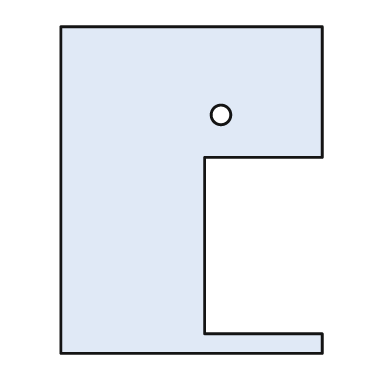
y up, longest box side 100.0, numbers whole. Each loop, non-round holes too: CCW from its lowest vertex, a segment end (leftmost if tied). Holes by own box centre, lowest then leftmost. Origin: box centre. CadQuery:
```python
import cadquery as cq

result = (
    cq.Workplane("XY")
    .moveTo(-40.0, -50.0)
    .lineTo(40.0, -50.0)
    .lineTo(40.0, -44.0)
    .lineTo(4.0, -44.0)
    .lineTo(4.0, 10.0)
    .lineTo(40.0, 10.0)
    .lineTo(40.0, 50.0)
    .lineTo(-40.0, 50.0)
    .close()
    .moveTo(9.0, 23.0)
    .circle(3.0)
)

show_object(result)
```